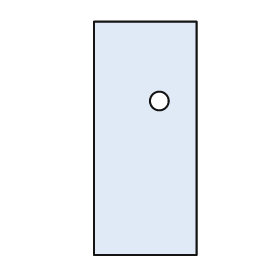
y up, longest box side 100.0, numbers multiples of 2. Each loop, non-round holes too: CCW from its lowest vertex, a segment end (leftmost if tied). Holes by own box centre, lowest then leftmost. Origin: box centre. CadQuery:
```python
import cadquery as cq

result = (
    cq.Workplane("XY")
    .moveTo(-22.0, -50.0)
    .lineTo(22.0, -50.0)
    .lineTo(22.0, 50.0)
    .lineTo(-22.0, 50.0)
    .close()
    .moveTo(6.0, 16.0)
    .circle(4.0)
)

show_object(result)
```